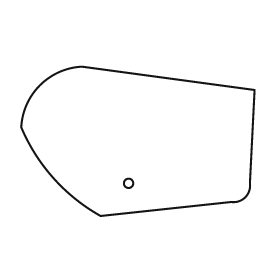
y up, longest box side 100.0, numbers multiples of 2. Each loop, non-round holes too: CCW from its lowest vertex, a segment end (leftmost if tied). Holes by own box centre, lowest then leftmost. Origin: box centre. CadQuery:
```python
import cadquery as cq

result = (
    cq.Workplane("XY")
    .moveTo(-16.0, -32.0)
    .lineTo(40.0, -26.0)
    .threePointArc((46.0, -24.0), (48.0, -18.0))
    .lineTo(50.0, 22.0)
    .lineTo(-24.0, 32.0)
    .threePointArc((-42.0, 24.0), (-50.0, 6.0))
    .threePointArc((-36.0, -16.0), (-16.0, -32.0))
    .close()
    .moveTo(-4.0, -18.0)
    .circle(2.0)
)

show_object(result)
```